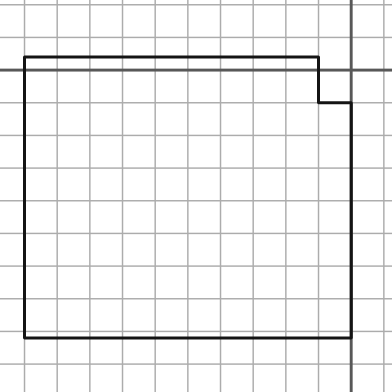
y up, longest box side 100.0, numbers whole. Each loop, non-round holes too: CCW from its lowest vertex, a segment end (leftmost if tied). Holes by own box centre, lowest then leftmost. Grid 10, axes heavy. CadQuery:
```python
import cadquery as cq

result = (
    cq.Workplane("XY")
    .moveTo(-100.0, -82.0)
    .lineTo(0.0, -82.0)
    .lineTo(0.0, -10.0)
    .lineTo(-10.0, -10.0)
    .lineTo(-10.0, 4.0)
    .lineTo(-100.0, 4.0)
    .close()
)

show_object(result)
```